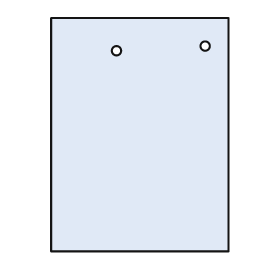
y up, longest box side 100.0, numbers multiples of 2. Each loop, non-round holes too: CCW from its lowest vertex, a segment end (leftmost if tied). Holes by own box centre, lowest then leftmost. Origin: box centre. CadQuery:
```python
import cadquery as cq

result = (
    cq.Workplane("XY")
    .moveTo(-38.0, -50.0)
    .lineTo(38.0, -50.0)
    .lineTo(38.0, 50.0)
    .lineTo(-38.0, 50.0)
    .close()
    .moveTo(-10.0, 36.0)
    .circle(2.0)
    .moveTo(28.0, 38.0)
    .circle(2.0)
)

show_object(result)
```